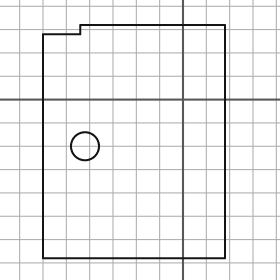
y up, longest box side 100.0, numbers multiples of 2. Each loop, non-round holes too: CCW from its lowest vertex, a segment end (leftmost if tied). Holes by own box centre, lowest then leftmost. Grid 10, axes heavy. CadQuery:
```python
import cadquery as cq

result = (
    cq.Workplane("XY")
    .moveTo(-60.0, -68.0)
    .lineTo(18.0, -68.0)
    .lineTo(18.0, 32.0)
    .lineTo(-44.0, 32.0)
    .lineTo(-44.0, 28.0)
    .lineTo(-60.0, 28.0)
    .close()
    .moveTo(-42.0, -20.0)
    .circle(6.0)
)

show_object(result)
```